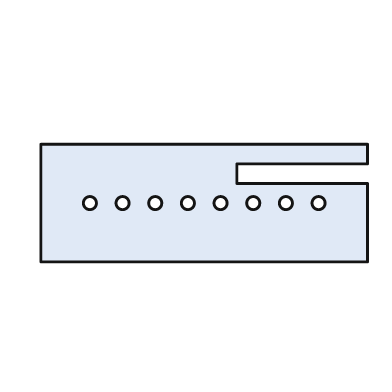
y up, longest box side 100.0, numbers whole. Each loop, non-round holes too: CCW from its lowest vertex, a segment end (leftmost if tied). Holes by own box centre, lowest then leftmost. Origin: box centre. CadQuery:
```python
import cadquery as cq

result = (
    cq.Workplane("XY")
    .moveTo(-50.0, -18.0)
    .lineTo(50.0, -18.0)
    .lineTo(50.0, 6.0)
    .lineTo(10.0, 6.0)
    .lineTo(10.0, 12.0)
    .lineTo(50.0, 12.0)
    .lineTo(50.0, 18.0)
    .lineTo(-50.0, 18.0)
    .close()
    .moveTo(-35.0, 0.0)
    .circle(2.0)
    .moveTo(-25.0, 0.0)
    .circle(2.0)
    .moveTo(-15.0, 0.0)
    .circle(2.0)
    .moveTo(-5.0, 0.0)
    .circle(2.0)
    .moveTo(5.0, 0.0)
    .circle(2.0)
    .moveTo(15.0, 0.0)
    .circle(2.0)
    .moveTo(25.0, 0.0)
    .circle(2.0)
    .moveTo(35.0, 0.0)
    .circle(2.0)
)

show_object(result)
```